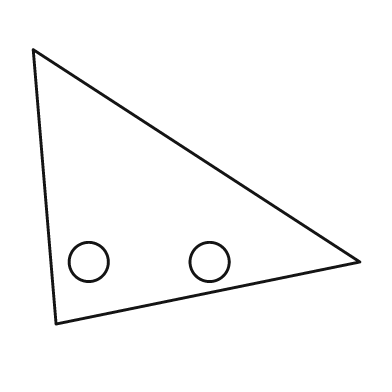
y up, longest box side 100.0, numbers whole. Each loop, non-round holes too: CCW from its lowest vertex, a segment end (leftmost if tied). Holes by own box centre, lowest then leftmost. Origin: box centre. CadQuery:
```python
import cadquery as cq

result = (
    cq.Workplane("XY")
    .moveTo(-43.0, -42.0)
    .lineTo(50.0, -23.0)
    .lineTo(-50.0, 42.0)
    .close()
    .moveTo(-33.0, -23.0)
    .circle(6.0)
    .moveTo(4.0, -23.0)
    .circle(6.0)
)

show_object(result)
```